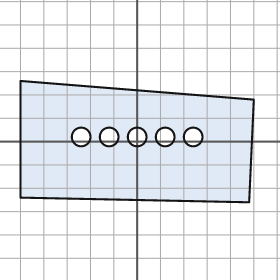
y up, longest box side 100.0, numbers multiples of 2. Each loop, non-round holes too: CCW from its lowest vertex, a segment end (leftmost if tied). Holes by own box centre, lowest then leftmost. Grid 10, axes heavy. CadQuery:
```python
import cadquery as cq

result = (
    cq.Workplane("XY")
    .moveTo(48.0, -26.0)
    .lineTo(50.0, 18.0)
    .lineTo(-50.0, 26.0)
    .lineTo(-50.0, -24.0)
    .close()
    .moveTo(-24.0, 2.0)
    .circle(4.0)
    .moveTo(-12.0, 2.0)
    .circle(4.0)
    .moveTo(0.0, 2.0)
    .circle(4.0)
    .moveTo(12.0, 2.0)
    .circle(4.0)
    .moveTo(24.0, 2.0)
    .circle(4.0)
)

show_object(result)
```